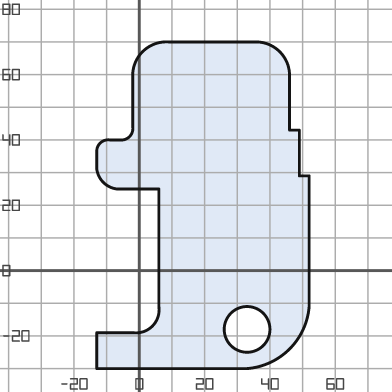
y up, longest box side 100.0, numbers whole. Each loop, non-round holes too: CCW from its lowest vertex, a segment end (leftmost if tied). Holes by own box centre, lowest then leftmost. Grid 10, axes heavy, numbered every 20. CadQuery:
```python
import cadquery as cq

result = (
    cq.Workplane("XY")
    .moveTo(-13.0, -30.0)
    .lineTo(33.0, -30.0)
    .threePointArc((46.0, -24.0), (52.0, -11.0))
    .lineTo(52.0, 29.0)
    .lineTo(49.0, 29.0)
    .lineTo(49.0, 43.0)
    .lineTo(46.0, 43.0)
    .lineTo(46.0, 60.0)
    .threePointArc((43.0, 67.0), (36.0, 70.0))
    .lineTo(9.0, 70.0)
    .threePointArc((1.0, 67.0), (-2.0, 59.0))
    .lineTo(-2.0, 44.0)
    .threePointArc((-3.0, 41.0), (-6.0, 40.0))
    .lineTo(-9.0, 40.0)
    .threePointArc((-12.0, 39.0), (-13.0, 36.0))
    .lineTo(-13.0, 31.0)
    .threePointArc((-11.0, 27.0), (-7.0, 25.0))
    .lineTo(6.0, 25.0)
    .lineTo(6.0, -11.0)
    .threePointArc((4.0, -17.0), (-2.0, -19.0))
    .lineTo(-13.0, -19.0)
    .close()
    .moveTo(33.0, -18.0)
    .circle(7.0)
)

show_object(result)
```